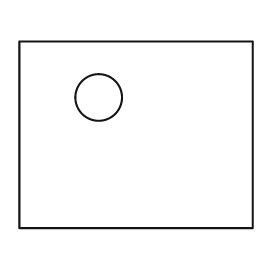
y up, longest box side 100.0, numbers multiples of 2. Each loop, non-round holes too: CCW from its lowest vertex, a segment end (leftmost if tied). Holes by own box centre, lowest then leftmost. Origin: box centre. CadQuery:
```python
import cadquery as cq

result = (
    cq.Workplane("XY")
    .moveTo(-50.0, -40.0)
    .lineTo(50.0, -40.0)
    .lineTo(50.0, 40.0)
    .lineTo(-50.0, 40.0)
    .close()
    .moveTo(-16.0, 16.0)
    .circle(10.0)
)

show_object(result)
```